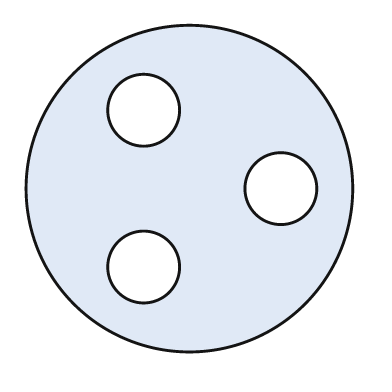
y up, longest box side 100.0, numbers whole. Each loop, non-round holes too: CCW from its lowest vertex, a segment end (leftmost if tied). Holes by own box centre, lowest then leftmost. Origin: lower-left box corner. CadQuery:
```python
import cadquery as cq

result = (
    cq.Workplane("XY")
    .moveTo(50.0, 50.0)
    .circle(50.0)
    .moveTo(36.0, 26.0)
    .circle(11.0)
    .moveTo(78.0, 50.0)
    .circle(11.0)
    .moveTo(36.0, 74.0)
    .circle(11.0)
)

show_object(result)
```